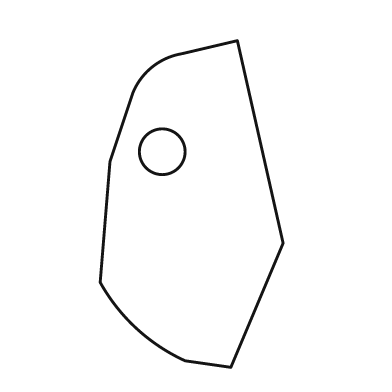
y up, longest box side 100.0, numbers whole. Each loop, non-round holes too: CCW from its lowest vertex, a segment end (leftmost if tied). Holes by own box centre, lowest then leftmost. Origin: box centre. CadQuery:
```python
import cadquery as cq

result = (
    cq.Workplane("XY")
    .moveTo(12.0, -50.0)
    .lineTo(28.0, -12.0)
    .lineTo(14.0, 50.0)
    .lineTo(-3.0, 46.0)
    .threePointArc((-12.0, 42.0), (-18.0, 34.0))
    .lineTo(-25.0, 13.0)
    .lineTo(-28.0, -24.0)
    .threePointArc((-17.0, -38.0), (-2.0, -48.0))
    .close()
    .moveTo(-9.0, 16.0)
    .circle(7.0)
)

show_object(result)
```